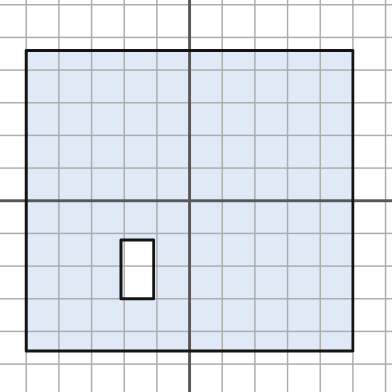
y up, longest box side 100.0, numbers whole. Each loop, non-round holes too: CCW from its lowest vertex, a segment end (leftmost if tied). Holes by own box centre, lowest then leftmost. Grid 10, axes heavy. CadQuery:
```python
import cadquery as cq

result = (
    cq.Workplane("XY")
    .moveTo(-50.0, -46.0)
    .lineTo(50.0, -46.0)
    .lineTo(50.0, 46.0)
    .lineTo(-50.0, 46.0)
    .close()
    .moveTo(-21.0, -30.0)
    .lineTo(-11.0, -30.0)
    .lineTo(-11.0, -12.0)
    .lineTo(-21.0, -12.0)
    .close()
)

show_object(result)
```